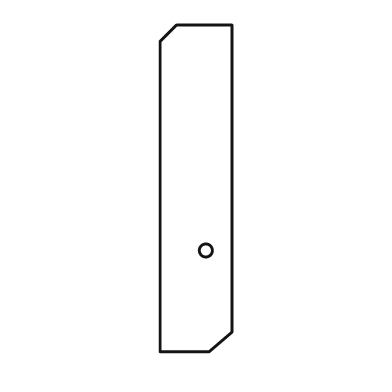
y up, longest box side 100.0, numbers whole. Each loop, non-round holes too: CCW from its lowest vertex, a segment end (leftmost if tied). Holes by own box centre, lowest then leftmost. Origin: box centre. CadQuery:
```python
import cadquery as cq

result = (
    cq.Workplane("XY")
    .moveTo(-11.0, -50.0)
    .lineTo(4.0, -50.0)
    .lineTo(11.0, -44.0)
    .lineTo(11.0, 50.0)
    .lineTo(-6.0, 50.0)
    .lineTo(-11.0, 45.0)
    .close()
    .moveTo(3.0, -19.0)
    .circle(2.0)
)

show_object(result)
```